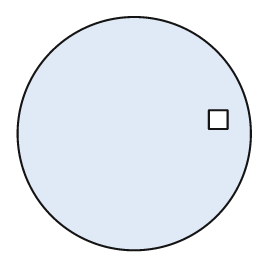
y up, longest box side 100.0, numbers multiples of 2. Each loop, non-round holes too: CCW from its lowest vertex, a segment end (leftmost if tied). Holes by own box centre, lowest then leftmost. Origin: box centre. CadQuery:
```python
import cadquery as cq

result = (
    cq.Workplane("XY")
    .moveTo(0.0, 0.0)
    .circle(50.0)
    .moveTo(32.0, 2.0)
    .lineTo(40.0, 2.0)
    .lineTo(40.0, 10.0)
    .lineTo(32.0, 10.0)
    .close()
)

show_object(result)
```